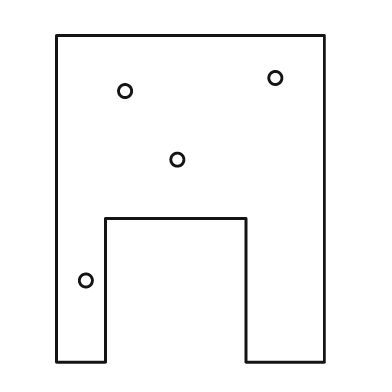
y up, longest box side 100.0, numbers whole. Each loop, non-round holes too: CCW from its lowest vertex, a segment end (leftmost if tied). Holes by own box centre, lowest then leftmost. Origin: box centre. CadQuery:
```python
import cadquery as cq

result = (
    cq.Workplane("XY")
    .moveTo(-41.0, -50.0)
    .lineTo(-26.0, -50.0)
    .lineTo(-26.0, -6.0)
    .lineTo(17.0, -6.0)
    .lineTo(17.0, -50.0)
    .lineTo(41.0, -50.0)
    .lineTo(41.0, 50.0)
    .lineTo(-41.0, 50.0)
    .close()
    .moveTo(-32.0, -25.0)
    .circle(2.0)
    .moveTo(-4.0, 12.0)
    .circle(2.0)
    .moveTo(-20.0, 33.0)
    .circle(2.0)
    .moveTo(26.0, 37.0)
    .circle(2.0)
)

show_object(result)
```